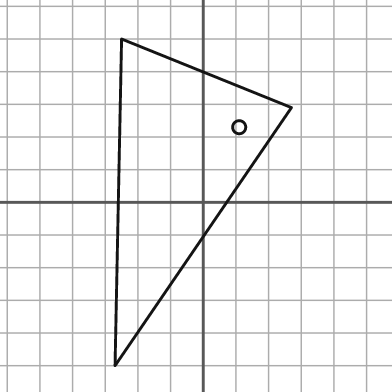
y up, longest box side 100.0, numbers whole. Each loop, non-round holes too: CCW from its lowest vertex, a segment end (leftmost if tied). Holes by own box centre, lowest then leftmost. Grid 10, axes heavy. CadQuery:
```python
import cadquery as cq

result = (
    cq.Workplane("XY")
    .moveTo(-27.0, -50.0)
    .lineTo(27.0, 29.0)
    .lineTo(-25.0, 50.0)
    .close()
    .moveTo(11.0, 23.0)
    .circle(2.0)
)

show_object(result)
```